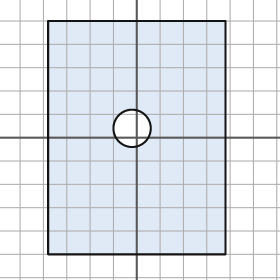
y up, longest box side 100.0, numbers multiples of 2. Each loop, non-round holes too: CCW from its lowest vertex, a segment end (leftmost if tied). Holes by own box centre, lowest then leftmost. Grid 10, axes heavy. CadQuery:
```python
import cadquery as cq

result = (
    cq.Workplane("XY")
    .moveTo(-38.0, -50.0)
    .lineTo(38.0, -50.0)
    .lineTo(38.0, 50.0)
    .lineTo(-38.0, 50.0)
    .close()
    .moveTo(-2.0, 4.0)
    .circle(8.0)
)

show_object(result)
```